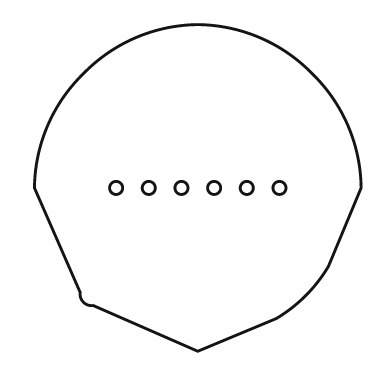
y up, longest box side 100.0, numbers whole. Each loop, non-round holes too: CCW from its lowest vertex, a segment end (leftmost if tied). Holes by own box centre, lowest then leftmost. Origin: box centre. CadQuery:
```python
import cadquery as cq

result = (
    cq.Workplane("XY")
    .moveTo(0.0, -50.0)
    .lineTo(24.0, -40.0)
    .threePointArc((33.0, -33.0), (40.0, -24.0))
    .lineTo(50.0, 0.0)
    .threePointArc((46.0, 19.0), (35.0, 35.0))
    .threePointArc((19.0, 46.0), (0.0, 50.0))
    .threePointArc((-19.0, 46.0), (-35.0, 35.0))
    .threePointArc((-46.0, 19.0), (-50.0, 0.0))
    .lineTo(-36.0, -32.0)
    .threePointArc((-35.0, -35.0), (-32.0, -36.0))
    .close()
    .moveTo(-25.0, 0.0)
    .circle(2.0)
    .moveTo(-15.0, 0.0)
    .circle(2.0)
    .moveTo(-5.0, 0.0)
    .circle(2.0)
    .moveTo(5.0, 0.0)
    .circle(2.0)
    .moveTo(15.0, 0.0)
    .circle(2.0)
    .moveTo(25.0, 0.0)
    .circle(2.0)
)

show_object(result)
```